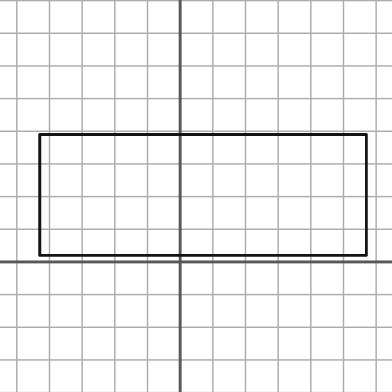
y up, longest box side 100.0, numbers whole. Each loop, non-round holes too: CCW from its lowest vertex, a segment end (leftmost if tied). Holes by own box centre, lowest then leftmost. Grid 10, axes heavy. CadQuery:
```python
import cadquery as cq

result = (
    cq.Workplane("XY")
    .moveTo(-43.0, 2.0)
    .lineTo(57.0, 2.0)
    .lineTo(57.0, 39.0)
    .lineTo(-43.0, 39.0)
    .close()
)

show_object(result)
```